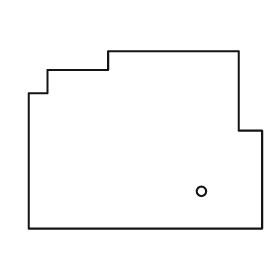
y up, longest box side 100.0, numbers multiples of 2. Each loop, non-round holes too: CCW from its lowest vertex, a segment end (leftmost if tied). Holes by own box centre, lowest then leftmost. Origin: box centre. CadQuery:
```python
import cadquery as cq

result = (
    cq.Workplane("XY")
    .moveTo(-50.0, -38.0)
    .lineTo(50.0, -38.0)
    .lineTo(50.0, 4.0)
    .lineTo(40.0, 4.0)
    .lineTo(40.0, 38.0)
    .lineTo(-16.0, 38.0)
    .lineTo(-16.0, 30.0)
    .lineTo(-42.0, 30.0)
    .lineTo(-42.0, 20.0)
    .lineTo(-50.0, 20.0)
    .close()
    .moveTo(24.0, -22.0)
    .circle(2.0)
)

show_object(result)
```